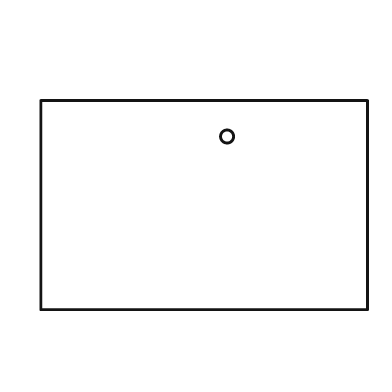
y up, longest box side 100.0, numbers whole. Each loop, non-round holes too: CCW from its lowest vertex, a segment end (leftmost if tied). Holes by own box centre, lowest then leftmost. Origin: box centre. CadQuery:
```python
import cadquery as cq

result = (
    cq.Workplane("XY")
    .moveTo(-50.0, -32.0)
    .lineTo(50.0, -32.0)
    .lineTo(50.0, 32.0)
    .lineTo(-50.0, 32.0)
    .close()
    .moveTo(7.0, 21.0)
    .circle(2.0)
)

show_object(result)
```